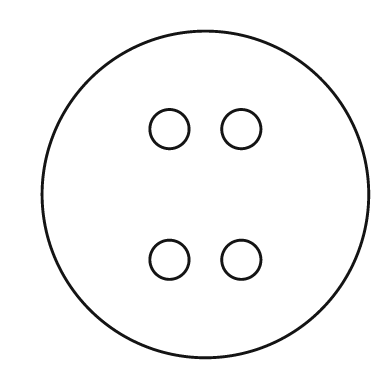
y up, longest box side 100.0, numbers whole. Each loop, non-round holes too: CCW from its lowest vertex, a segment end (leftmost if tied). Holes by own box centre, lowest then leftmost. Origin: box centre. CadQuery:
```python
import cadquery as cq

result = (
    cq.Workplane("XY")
    .moveTo(0.0, 0.0)
    .circle(50.0)
    .moveTo(-11.0, -20.0)
    .circle(6.0)
    .moveTo(11.0, -20.0)
    .circle(6.0)
    .moveTo(-11.0, 20.0)
    .circle(6.0)
    .moveTo(11.0, 20.0)
    .circle(6.0)
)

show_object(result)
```